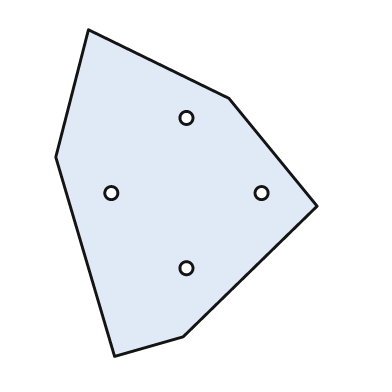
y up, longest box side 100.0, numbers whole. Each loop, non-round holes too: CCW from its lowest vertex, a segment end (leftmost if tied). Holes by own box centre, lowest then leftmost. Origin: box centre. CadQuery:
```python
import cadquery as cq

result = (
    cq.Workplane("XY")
    .moveTo(-22.0, -50.0)
    .lineTo(-1.0, -44.0)
    .lineTo(40.0, -4.0)
    .lineTo(13.0, 29.0)
    .lineTo(-30.0, 50.0)
    .lineTo(-40.0, 11.0)
    .close()
    .moveTo(0.0, -23.0)
    .circle(2.0)
    .moveTo(-23.0, 0.0)
    .circle(2.0)
    .moveTo(23.0, 0.0)
    .circle(2.0)
    .moveTo(0.0, 23.0)
    .circle(2.0)
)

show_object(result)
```